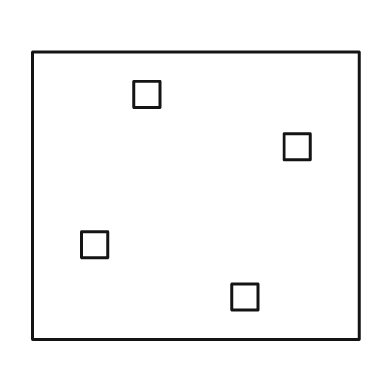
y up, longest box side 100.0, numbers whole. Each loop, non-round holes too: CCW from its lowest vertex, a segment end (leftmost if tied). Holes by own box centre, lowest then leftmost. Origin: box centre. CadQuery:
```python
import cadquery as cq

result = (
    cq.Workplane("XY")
    .moveTo(-50.0, -44.0)
    .lineTo(50.0, -44.0)
    .lineTo(50.0, 44.0)
    .lineTo(-50.0, 44.0)
    .close()
    .moveTo(11.0, -35.0)
    .lineTo(19.0, -35.0)
    .lineTo(19.0, -27.0)
    .lineTo(11.0, -27.0)
    .close()
    .moveTo(-35.0, -19.0)
    .lineTo(-27.0, -19.0)
    .lineTo(-27.0, -11.0)
    .lineTo(-35.0, -11.0)
    .close()
    .moveTo(27.0, 11.0)
    .lineTo(35.0, 11.0)
    .lineTo(35.0, 19.0)
    .lineTo(27.0, 19.0)
    .close()
    .moveTo(-19.0, 27.0)
    .lineTo(-11.0, 27.0)
    .lineTo(-11.0, 35.0)
    .lineTo(-19.0, 35.0)
    .close()
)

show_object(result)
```